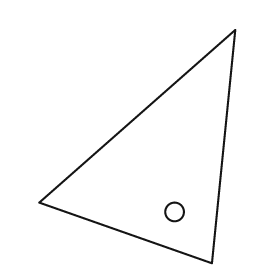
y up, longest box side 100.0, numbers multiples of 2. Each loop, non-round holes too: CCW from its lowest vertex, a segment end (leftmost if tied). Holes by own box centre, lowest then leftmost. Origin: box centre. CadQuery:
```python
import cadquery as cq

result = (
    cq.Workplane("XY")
    .moveTo(32.0, -50.0)
    .lineTo(42.0, 50.0)
    .lineTo(-42.0, -24.0)
    .close()
    .moveTo(16.0, -28.0)
    .circle(4.0)
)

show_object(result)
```